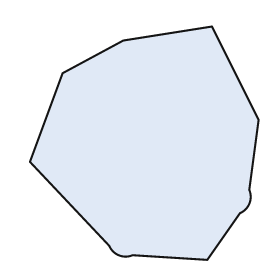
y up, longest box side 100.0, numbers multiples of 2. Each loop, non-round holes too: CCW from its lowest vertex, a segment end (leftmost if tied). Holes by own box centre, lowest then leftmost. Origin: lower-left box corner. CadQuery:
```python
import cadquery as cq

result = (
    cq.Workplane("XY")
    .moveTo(76.0, 0.0)
    .lineTo(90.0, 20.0)
    .threePointArc((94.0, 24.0), (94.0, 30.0))
    .lineTo(98.0, 60.0)
    .lineTo(78.0, 100.0)
    .lineTo(40.0, 94.0)
    .lineTo(14.0, 80.0)
    .lineTo(0.0, 42.0)
    .lineTo(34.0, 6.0)
    .threePointArc((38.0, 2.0), (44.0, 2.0))
    .close()
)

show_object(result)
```